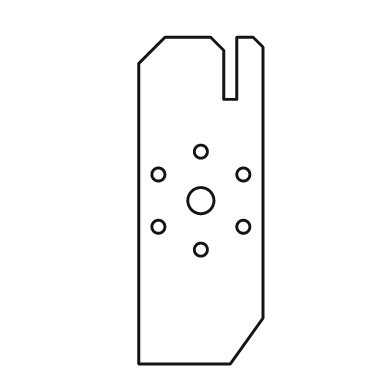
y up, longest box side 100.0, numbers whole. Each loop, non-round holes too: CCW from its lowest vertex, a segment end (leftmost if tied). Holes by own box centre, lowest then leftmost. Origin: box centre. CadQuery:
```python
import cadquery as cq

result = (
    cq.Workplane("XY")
    .moveTo(-19.0, -50.0)
    .lineTo(9.0, -50.0)
    .lineTo(19.0, -36.0)
    .lineTo(19.0, 47.0)
    .lineTo(16.0, 50.0)
    .lineTo(11.0, 50.0)
    .lineTo(11.0, 31.0)
    .lineTo(7.0, 31.0)
    .lineTo(7.0, 46.0)
    .lineTo(3.0, 50.0)
    .lineTo(-11.0, 50.0)
    .lineTo(-19.0, 42.0)
    .close()
    .moveTo(0.0, -15.0)
    .circle(2.0)
    .moveTo(-13.0, -8.0)
    .circle(2.0)
    .moveTo(13.0, -8.0)
    .circle(2.0)
    .moveTo(0.0, 0.0)
    .circle(4.0)
    .moveTo(-13.0, 8.0)
    .circle(2.0)
    .moveTo(13.0, 8.0)
    .circle(2.0)
    .moveTo(0.0, 15.0)
    .circle(2.0)
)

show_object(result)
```